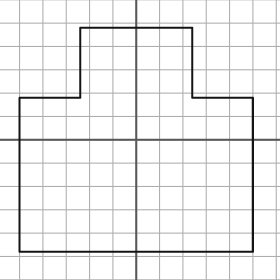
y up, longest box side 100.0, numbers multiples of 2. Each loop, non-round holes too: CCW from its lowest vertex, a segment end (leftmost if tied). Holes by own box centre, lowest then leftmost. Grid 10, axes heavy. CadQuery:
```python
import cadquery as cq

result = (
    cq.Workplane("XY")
    .moveTo(-50.0, -48.0)
    .lineTo(50.0, -48.0)
    .lineTo(50.0, 18.0)
    .lineTo(24.0, 18.0)
    .lineTo(24.0, 48.0)
    .lineTo(-24.0, 48.0)
    .lineTo(-24.0, 18.0)
    .lineTo(-50.0, 18.0)
    .close()
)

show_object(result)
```